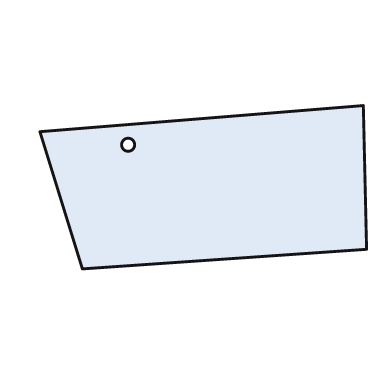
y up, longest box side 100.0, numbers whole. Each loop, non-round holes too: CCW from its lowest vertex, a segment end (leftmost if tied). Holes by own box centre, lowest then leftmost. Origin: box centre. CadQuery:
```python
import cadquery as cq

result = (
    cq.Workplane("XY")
    .moveTo(-37.0, -25.0)
    .lineTo(50.0, -19.0)
    .lineTo(49.0, 25.0)
    .lineTo(-50.0, 17.0)
    .close()
    .moveTo(-23.0, 13.0)
    .circle(2.0)
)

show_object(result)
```